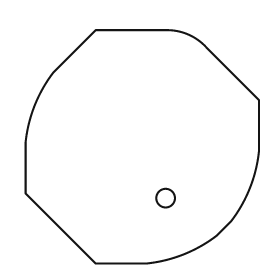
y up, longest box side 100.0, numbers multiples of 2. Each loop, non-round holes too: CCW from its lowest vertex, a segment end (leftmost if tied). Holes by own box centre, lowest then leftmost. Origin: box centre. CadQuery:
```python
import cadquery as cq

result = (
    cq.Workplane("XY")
    .moveTo(-20.0, -50.0)
    .lineTo(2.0, -50.0)
    .threePointArc((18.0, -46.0), (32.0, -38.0))
    .lineTo(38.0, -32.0)
    .threePointArc((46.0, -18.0), (50.0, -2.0))
    .lineTo(50.0, 20.0)
    .lineTo(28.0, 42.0)
    .threePointArc((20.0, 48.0), (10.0, 50.0))
    .lineTo(-20.0, 50.0)
    .lineTo(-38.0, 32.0)
    .threePointArc((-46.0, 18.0), (-50.0, 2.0))
    .lineTo(-50.0, -20.0)
    .close()
    .moveTo(10.0, -22.0)
    .circle(4.0)
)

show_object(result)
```